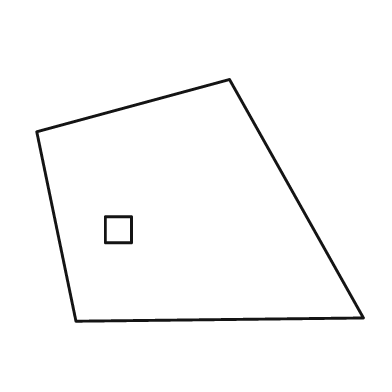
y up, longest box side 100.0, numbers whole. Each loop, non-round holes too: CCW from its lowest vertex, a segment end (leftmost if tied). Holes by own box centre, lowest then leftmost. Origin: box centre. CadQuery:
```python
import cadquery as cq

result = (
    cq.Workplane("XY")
    .moveTo(-38.0, -37.0)
    .lineTo(50.0, -36.0)
    .lineTo(9.0, 37.0)
    .lineTo(-50.0, 21.0)
    .close()
    .moveTo(-29.0, -13.0)
    .lineTo(-21.0, -13.0)
    .lineTo(-21.0, -5.0)
    .lineTo(-29.0, -5.0)
    .close()
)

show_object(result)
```